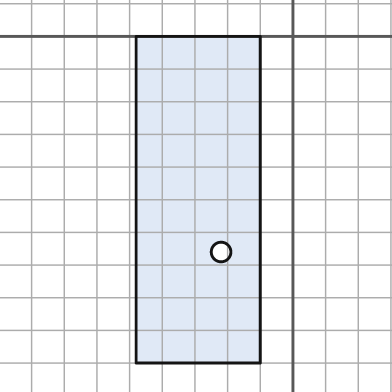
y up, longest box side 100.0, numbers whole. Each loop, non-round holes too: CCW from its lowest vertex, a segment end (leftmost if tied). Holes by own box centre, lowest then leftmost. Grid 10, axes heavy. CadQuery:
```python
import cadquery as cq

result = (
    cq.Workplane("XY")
    .moveTo(-48.0, -100.0)
    .lineTo(-10.0, -100.0)
    .lineTo(-10.0, 0.0)
    .lineTo(-48.0, 0.0)
    .close()
    .moveTo(-22.0, -66.0)
    .circle(3.0)
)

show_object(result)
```